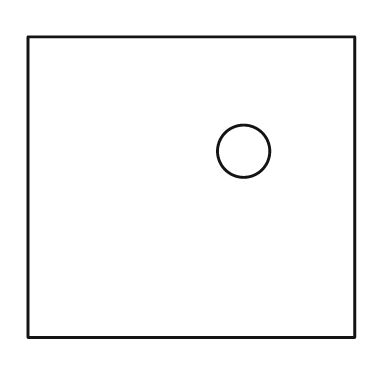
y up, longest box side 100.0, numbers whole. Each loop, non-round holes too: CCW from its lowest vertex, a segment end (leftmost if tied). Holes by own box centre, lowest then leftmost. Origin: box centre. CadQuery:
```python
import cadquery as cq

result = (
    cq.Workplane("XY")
    .moveTo(-50.0, -46.0)
    .lineTo(50.0, -46.0)
    .lineTo(50.0, 46.0)
    .lineTo(-50.0, 46.0)
    .close()
    .moveTo(16.0, 11.0)
    .circle(8.0)
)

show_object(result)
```